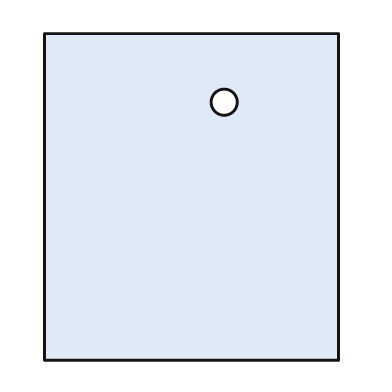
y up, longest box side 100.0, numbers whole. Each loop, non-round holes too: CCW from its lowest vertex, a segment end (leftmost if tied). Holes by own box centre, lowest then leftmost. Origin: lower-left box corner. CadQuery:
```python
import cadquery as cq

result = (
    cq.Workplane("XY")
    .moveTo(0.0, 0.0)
    .lineTo(90.0, 0.0)
    .lineTo(90.0, 100.0)
    .lineTo(0.0, 100.0)
    .close()
    .moveTo(55.0, 79.0)
    .circle(4.0)
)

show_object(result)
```